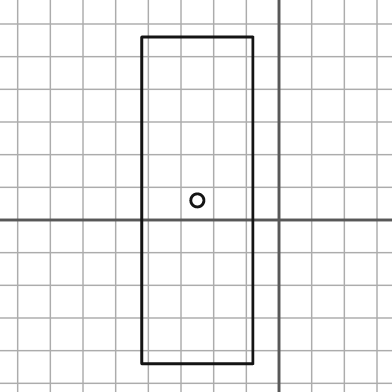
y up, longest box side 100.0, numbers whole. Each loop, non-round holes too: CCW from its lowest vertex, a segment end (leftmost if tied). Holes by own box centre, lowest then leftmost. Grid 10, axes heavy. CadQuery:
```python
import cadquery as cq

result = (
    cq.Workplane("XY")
    .moveTo(-42.0, -44.0)
    .lineTo(-8.0, -44.0)
    .lineTo(-8.0, 56.0)
    .lineTo(-42.0, 56.0)
    .close()
    .moveTo(-25.0, 6.0)
    .circle(2.0)
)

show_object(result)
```